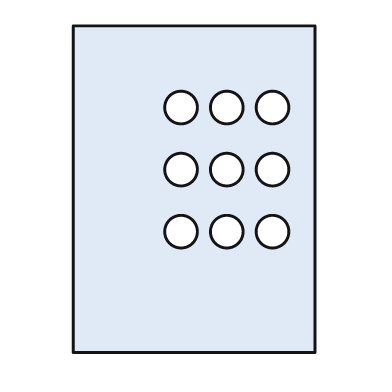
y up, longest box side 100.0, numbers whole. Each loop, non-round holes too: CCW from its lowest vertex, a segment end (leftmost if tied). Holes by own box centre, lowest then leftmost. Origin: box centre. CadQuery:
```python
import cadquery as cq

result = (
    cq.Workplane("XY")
    .moveTo(-37.0, -50.0)
    .lineTo(37.0, -50.0)
    .lineTo(37.0, 50.0)
    .lineTo(-37.0, 50.0)
    .close()
    .moveTo(-4.0, -13.0)
    .circle(5.0)
    .moveTo(10.0, -13.0)
    .circle(5.0)
    .moveTo(24.0, -13.0)
    .circle(5.0)
    .moveTo(-4.0, 6.0)
    .circle(5.0)
    .moveTo(10.0, 6.0)
    .circle(5.0)
    .moveTo(24.0, 6.0)
    .circle(5.0)
    .moveTo(-4.0, 25.0)
    .circle(5.0)
    .moveTo(10.0, 25.0)
    .circle(5.0)
    .moveTo(24.0, 25.0)
    .circle(5.0)
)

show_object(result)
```